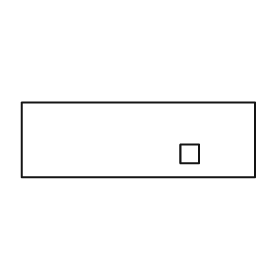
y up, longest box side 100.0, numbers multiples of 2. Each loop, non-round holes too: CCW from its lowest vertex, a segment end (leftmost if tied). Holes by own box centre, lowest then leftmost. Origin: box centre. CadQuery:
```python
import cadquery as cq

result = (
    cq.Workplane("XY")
    .moveTo(-50.0, -16.0)
    .lineTo(50.0, -16.0)
    .lineTo(50.0, 16.0)
    .lineTo(-50.0, 16.0)
    .close()
    .moveTo(18.0, -10.0)
    .lineTo(26.0, -10.0)
    .lineTo(26.0, -2.0)
    .lineTo(18.0, -2.0)
    .close()
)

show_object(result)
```